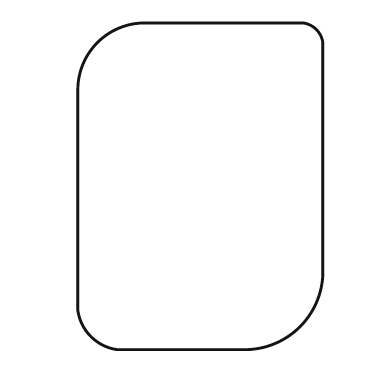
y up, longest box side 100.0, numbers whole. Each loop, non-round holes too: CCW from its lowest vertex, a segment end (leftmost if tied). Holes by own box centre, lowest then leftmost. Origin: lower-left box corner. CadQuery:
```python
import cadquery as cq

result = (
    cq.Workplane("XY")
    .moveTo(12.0, 0.0)
    .lineTo(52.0, 0.0)
    .threePointArc((68.0, 7.0), (75.0, 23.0))
    .lineTo(75.0, 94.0)
    .threePointArc((73.0, 98.0), (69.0, 100.0))
    .lineTo(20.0, 100.0)
    .threePointArc((6.0, 94.0), (0.0, 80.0))
    .lineTo(0.0, 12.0)
    .threePointArc((4.0, 4.0), (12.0, 0.0))
    .close()
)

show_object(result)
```